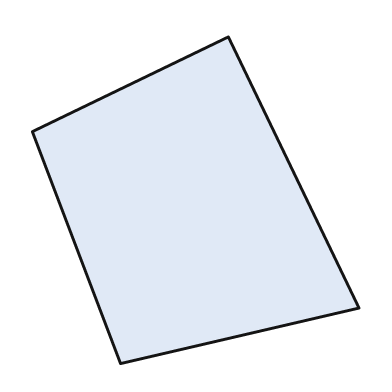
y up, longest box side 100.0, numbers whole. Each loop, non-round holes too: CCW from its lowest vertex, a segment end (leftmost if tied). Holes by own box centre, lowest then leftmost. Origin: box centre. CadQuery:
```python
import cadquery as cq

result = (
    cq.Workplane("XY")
    .moveTo(-23.0, -50.0)
    .lineTo(50.0, -33.0)
    .lineTo(10.0, 50.0)
    .lineTo(-50.0, 21.0)
    .close()
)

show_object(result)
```